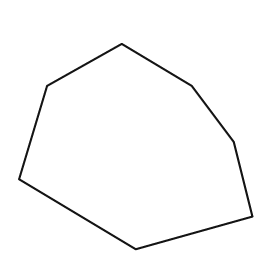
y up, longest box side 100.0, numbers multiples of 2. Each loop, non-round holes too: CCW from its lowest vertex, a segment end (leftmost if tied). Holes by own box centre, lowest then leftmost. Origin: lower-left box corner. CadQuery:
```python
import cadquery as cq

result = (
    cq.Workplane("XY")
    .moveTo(50.0, 0.0)
    .lineTo(100.0, 14.0)
    .lineTo(92.0, 46.0)
    .lineTo(74.0, 70.0)
    .lineTo(44.0, 88.0)
    .lineTo(12.0, 70.0)
    .lineTo(0.0, 30.0)
    .close()
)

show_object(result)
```